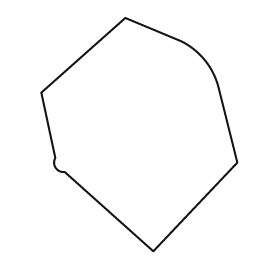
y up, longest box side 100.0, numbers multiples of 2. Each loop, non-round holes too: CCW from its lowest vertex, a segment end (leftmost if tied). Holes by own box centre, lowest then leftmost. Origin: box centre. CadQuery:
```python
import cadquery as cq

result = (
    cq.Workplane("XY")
    .moveTo(6.0, -50.0)
    .lineTo(42.0, -12.0)
    .lineTo(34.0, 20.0)
    .threePointArc((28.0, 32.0), (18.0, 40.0))
    .lineTo(-6.0, 50.0)
    .lineTo(-42.0, 18.0)
    .lineTo(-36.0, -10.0)
    .threePointArc((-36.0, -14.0), (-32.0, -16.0))
    .close()
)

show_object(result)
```